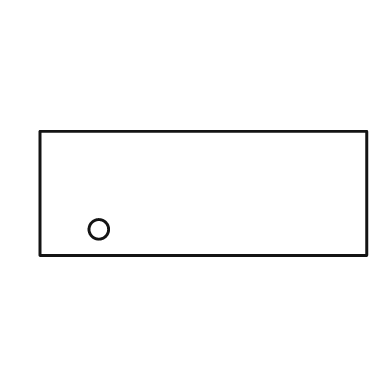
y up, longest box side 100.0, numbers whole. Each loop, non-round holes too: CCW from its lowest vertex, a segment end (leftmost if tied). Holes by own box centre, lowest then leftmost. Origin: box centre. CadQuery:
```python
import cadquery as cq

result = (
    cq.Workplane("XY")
    .moveTo(-50.0, -19.0)
    .lineTo(50.0, -19.0)
    .lineTo(50.0, 19.0)
    .lineTo(-50.0, 19.0)
    .close()
    .moveTo(-32.0, -11.0)
    .circle(3.0)
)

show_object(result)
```